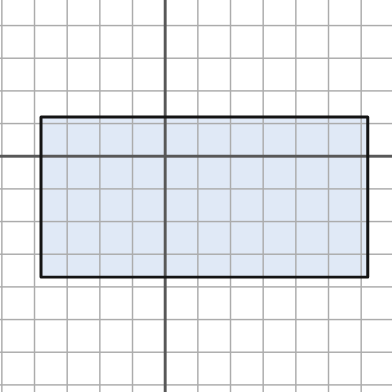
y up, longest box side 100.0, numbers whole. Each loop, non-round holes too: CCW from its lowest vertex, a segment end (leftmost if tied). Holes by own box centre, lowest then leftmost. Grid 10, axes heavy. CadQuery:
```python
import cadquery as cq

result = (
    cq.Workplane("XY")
    .moveTo(-38.0, -37.0)
    .lineTo(62.0, -37.0)
    .lineTo(62.0, 12.0)
    .lineTo(-38.0, 12.0)
    .close()
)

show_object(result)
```